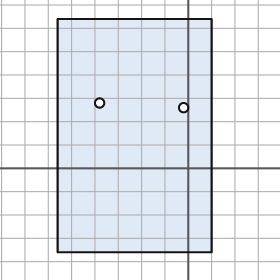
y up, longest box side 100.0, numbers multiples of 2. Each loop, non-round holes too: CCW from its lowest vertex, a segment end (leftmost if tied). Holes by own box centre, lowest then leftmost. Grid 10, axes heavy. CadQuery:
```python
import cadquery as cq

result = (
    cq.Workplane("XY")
    .moveTo(-56.0, -36.0)
    .lineTo(10.0, -36.0)
    .lineTo(10.0, 64.0)
    .lineTo(-56.0, 64.0)
    .close()
    .moveTo(-2.0, 26.0)
    .circle(2.0)
    .moveTo(-38.0, 28.0)
    .circle(2.0)
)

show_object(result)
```